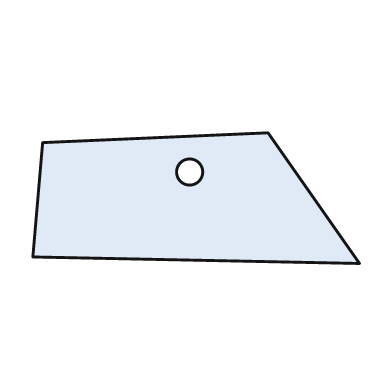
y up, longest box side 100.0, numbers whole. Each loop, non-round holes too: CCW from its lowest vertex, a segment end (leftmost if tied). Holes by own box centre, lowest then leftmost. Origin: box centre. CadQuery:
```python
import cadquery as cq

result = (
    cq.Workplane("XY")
    .moveTo(50.0, -20.0)
    .lineTo(22.0, 20.0)
    .lineTo(-47.0, 17.0)
    .lineTo(-50.0, -18.0)
    .close()
    .moveTo(-2.0, 8.0)
    .circle(4.0)
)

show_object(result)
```